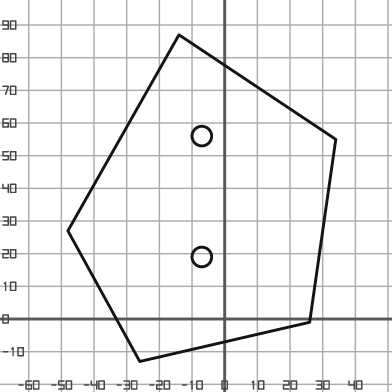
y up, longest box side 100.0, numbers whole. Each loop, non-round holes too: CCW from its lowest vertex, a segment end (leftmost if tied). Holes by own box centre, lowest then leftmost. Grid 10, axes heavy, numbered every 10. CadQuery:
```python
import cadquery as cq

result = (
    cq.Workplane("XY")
    .moveTo(-26.0, -13.0)
    .lineTo(26.0, -1.0)
    .lineTo(34.0, 55.0)
    .lineTo(-14.0, 87.0)
    .lineTo(-48.0, 27.0)
    .close()
    .moveTo(-7.0, 19.0)
    .circle(3.0)
    .moveTo(-7.0, 56.0)
    .circle(3.0)
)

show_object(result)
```